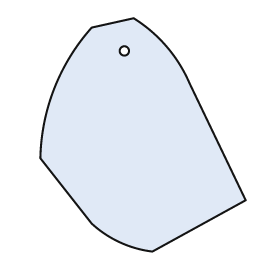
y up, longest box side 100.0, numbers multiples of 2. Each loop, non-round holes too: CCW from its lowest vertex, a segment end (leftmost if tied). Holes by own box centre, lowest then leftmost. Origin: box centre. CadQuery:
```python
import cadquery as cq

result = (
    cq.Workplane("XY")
    .moveTo(4.0, -50.0)
    .lineTo(44.0, -28.0)
    .lineTo(20.0, 22.0)
    .threePointArc((10.0, 38.0), (-4.0, 50.0))
    .lineTo(-22.0, 46.0)
    .threePointArc((-38.0, 20.0), (-44.0, -10.0))
    .lineTo(-22.0, -38.0)
    .threePointArc((-10.0, -46.0), (4.0, -50.0))
    .close()
    .moveTo(-8.0, 36.0)
    .circle(2.0)
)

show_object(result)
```